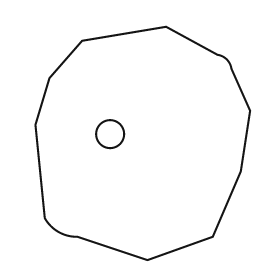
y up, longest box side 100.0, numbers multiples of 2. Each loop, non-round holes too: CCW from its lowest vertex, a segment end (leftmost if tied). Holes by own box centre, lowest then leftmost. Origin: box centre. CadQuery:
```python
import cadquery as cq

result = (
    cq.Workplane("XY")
    .moveTo(2.0, -50.0)
    .lineTo(30.0, -40.0)
    .lineTo(42.0, -12.0)
    .lineTo(46.0, 14.0)
    .lineTo(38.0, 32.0)
    .threePointArc((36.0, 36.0), (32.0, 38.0))
    .lineTo(10.0, 50.0)
    .lineTo(-26.0, 44.0)
    .lineTo(-40.0, 28.0)
    .lineTo(-46.0, 8.0)
    .lineTo(-42.0, -32.0)
    .threePointArc((-36.0, -38.0), (-28.0, -40.0))
    .close()
    .moveTo(-14.0, 4.0)
    .circle(6.0)
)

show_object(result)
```